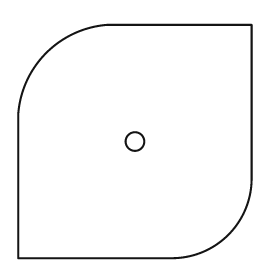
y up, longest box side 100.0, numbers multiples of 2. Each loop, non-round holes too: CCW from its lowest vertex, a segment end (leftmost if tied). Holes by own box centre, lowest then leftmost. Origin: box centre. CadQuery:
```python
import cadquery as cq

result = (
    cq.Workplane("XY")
    .moveTo(-50.0, -50.0)
    .lineTo(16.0, -50.0)
    .threePointArc((40.0, -40.0), (50.0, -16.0))
    .lineTo(50.0, 50.0)
    .lineTo(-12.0, 50.0)
    .threePointArc((-38.0, 38.0), (-50.0, 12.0))
    .close()
    .moveTo(0.0, 0.0)
    .circle(4.0)
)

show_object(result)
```